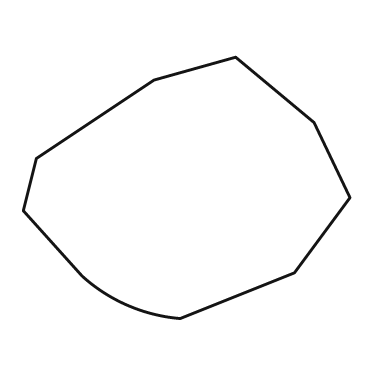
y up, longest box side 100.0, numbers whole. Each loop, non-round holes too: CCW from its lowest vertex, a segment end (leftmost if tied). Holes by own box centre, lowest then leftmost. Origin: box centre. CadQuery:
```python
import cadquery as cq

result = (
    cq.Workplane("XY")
    .moveTo(-2.0, -40.0)
    .lineTo(33.0, -26.0)
    .lineTo(50.0, -3.0)
    .lineTo(39.0, 20.0)
    .lineTo(15.0, 40.0)
    .lineTo(-10.0, 33.0)
    .lineTo(-46.0, 9.0)
    .lineTo(-50.0, -7.0)
    .lineTo(-32.0, -27.0)
    .threePointArc((-18.0, -36.0), (-2.0, -40.0))
    .close()
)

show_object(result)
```